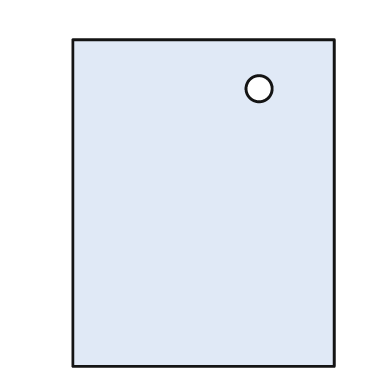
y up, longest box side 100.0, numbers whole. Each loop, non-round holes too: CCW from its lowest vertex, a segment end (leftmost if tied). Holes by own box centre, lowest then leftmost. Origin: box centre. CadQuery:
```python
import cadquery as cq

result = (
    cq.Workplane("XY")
    .moveTo(-40.0, -50.0)
    .lineTo(40.0, -50.0)
    .lineTo(40.0, 50.0)
    .lineTo(-40.0, 50.0)
    .close()
    .moveTo(17.0, 35.0)
    .circle(4.0)
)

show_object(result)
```